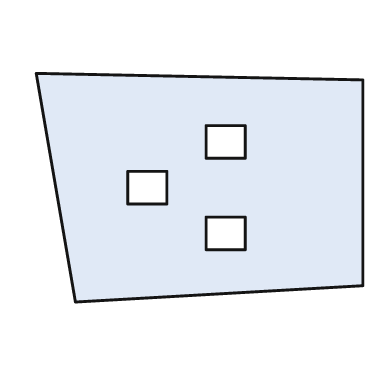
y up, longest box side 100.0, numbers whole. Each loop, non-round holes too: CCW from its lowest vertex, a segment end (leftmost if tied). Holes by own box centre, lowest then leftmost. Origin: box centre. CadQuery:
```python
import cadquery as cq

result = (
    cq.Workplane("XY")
    .moveTo(-38.0, -35.0)
    .lineTo(50.0, -30.0)
    .lineTo(50.0, 33.0)
    .lineTo(-50.0, 35.0)
    .close()
    .moveTo(2.0, -19.0)
    .lineTo(14.0, -19.0)
    .lineTo(14.0, -9.0)
    .lineTo(2.0, -9.0)
    .close()
    .moveTo(-22.0, -5.0)
    .lineTo(-10.0, -5.0)
    .lineTo(-10.0, 5.0)
    .lineTo(-22.0, 5.0)
    .close()
    .moveTo(2.0, 9.0)
    .lineTo(14.0, 9.0)
    .lineTo(14.0, 19.0)
    .lineTo(2.0, 19.0)
    .close()
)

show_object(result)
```